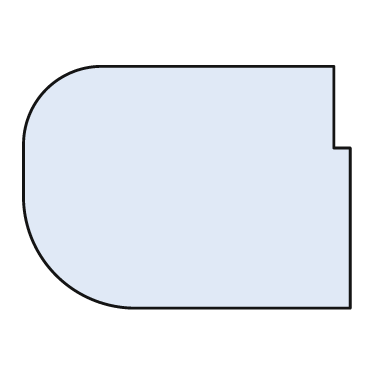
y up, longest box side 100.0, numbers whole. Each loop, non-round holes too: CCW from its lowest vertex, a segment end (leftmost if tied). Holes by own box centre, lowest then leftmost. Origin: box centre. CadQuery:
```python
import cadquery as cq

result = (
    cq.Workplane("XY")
    .moveTo(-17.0, -37.0)
    .lineTo(50.0, -37.0)
    .lineTo(50.0, 12.0)
    .lineTo(45.0, 12.0)
    .lineTo(45.0, 37.0)
    .lineTo(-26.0, 37.0)
    .threePointArc((-43.0, 30.0), (-50.0, 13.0))
    .lineTo(-50.0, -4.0)
    .threePointArc((-40.0, -27.0), (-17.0, -37.0))
    .close()
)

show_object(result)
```